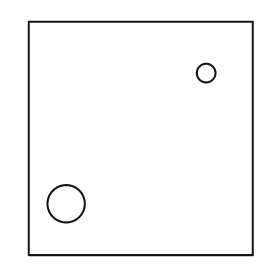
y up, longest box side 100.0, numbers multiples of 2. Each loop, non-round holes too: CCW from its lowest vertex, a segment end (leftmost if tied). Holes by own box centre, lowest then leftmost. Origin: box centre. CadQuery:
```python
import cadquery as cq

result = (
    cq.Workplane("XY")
    .moveTo(-48.0, -50.0)
    .lineTo(48.0, -50.0)
    .lineTo(48.0, 50.0)
    .lineTo(-48.0, 50.0)
    .close()
    .moveTo(-32.0, -28.0)
    .circle(8.0)
    .moveTo(28.0, 28.0)
    .circle(4.0)
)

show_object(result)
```